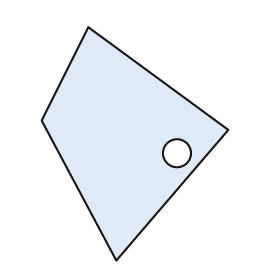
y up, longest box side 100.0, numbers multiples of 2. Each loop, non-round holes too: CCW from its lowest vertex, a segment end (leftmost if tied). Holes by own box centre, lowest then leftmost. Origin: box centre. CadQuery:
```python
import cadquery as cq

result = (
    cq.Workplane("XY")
    .moveTo(-8.0, -50.0)
    .lineTo(40.0, 6.0)
    .lineTo(-20.0, 50.0)
    .lineTo(-40.0, 10.0)
    .close()
    .moveTo(18.0, -4.0)
    .circle(6.0)
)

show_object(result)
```